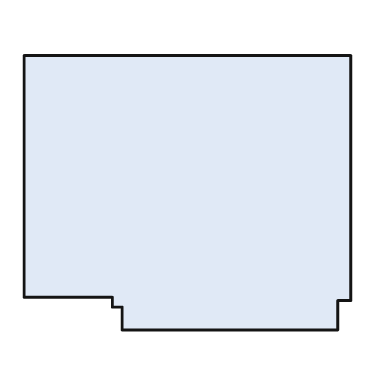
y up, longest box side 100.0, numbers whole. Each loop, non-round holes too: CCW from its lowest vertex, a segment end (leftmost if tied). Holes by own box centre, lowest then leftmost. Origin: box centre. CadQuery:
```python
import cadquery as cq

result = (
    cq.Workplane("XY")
    .moveTo(-20.0, -42.0)
    .lineTo(46.0, -42.0)
    .lineTo(46.0, -33.0)
    .lineTo(50.0, -33.0)
    .lineTo(50.0, 42.0)
    .lineTo(-50.0, 42.0)
    .lineTo(-50.0, -32.0)
    .lineTo(-23.0, -32.0)
    .lineTo(-23.0, -35.0)
    .lineTo(-20.0, -35.0)
    .close()
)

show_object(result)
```